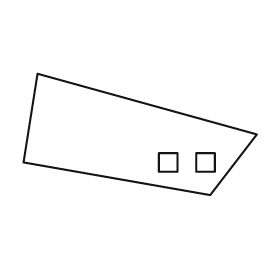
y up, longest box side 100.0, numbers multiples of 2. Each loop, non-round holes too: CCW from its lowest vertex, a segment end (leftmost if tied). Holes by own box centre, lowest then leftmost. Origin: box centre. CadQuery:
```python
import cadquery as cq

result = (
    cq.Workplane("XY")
    .moveTo(30.0, -26.0)
    .lineTo(50.0, 0.0)
    .lineTo(-44.0, 26.0)
    .lineTo(-50.0, -12.0)
    .close()
    .moveTo(8.0, -16.0)
    .lineTo(16.0, -16.0)
    .lineTo(16.0, -8.0)
    .lineTo(8.0, -8.0)
    .close()
    .moveTo(24.0, -16.0)
    .lineTo(32.0, -16.0)
    .lineTo(32.0, -8.0)
    .lineTo(24.0, -8.0)
    .close()
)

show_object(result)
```